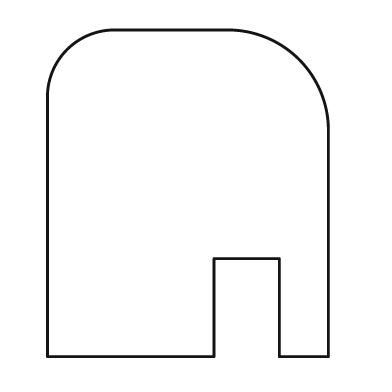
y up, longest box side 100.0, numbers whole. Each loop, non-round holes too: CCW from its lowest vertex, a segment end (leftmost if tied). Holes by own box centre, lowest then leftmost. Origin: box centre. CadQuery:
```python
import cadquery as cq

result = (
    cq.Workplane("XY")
    .moveTo(-43.0, -50.0)
    .lineTo(8.0, -50.0)
    .lineTo(8.0, -20.0)
    .lineTo(28.0, -20.0)
    .lineTo(28.0, -50.0)
    .lineTo(43.0, -50.0)
    .lineTo(43.0, 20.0)
    .threePointArc((34.0, 41.0), (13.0, 50.0))
    .lineTo(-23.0, 50.0)
    .threePointArc((-37.0, 44.0), (-43.0, 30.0))
    .close()
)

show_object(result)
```